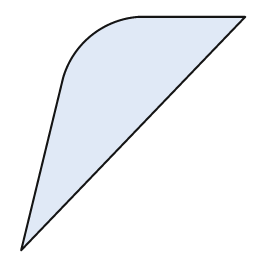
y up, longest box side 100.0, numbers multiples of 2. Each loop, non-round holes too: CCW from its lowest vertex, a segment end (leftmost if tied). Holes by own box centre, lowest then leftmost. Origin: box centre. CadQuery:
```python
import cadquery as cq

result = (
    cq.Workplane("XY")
    .moveTo(-48.0, -50.0)
    .lineTo(48.0, 50.0)
    .lineTo(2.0, 50.0)
    .threePointArc((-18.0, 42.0), (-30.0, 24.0))
    .close()
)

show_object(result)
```